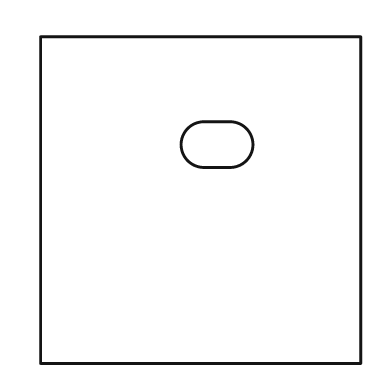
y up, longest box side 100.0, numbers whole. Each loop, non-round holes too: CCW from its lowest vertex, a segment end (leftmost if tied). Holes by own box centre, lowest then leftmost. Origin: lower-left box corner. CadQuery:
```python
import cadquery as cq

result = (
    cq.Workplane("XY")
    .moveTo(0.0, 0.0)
    .lineTo(98.0, 0.0)
    .lineTo(98.0, 100.0)
    .lineTo(0.0, 100.0)
    .close()
    .moveTo(50.0, 60.0)
    .lineTo(58.0, 60.0)
    .threePointArc((65.0, 67.0), (58.0, 74.0))
    .lineTo(50.0, 74.0)
    .threePointArc((43.0, 67.0), (50.0, 60.0))
    .close()
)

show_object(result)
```